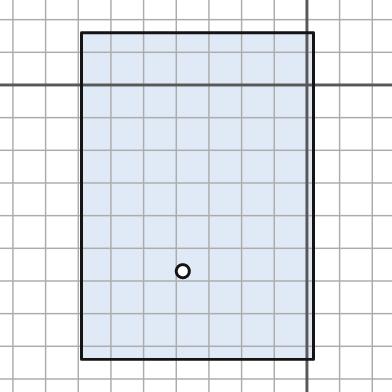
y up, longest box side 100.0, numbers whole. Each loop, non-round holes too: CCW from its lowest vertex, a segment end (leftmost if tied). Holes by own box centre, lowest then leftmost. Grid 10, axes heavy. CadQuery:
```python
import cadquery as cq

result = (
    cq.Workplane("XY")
    .moveTo(-69.0, -84.0)
    .lineTo(2.0, -84.0)
    .lineTo(2.0, 16.0)
    .lineTo(-69.0, 16.0)
    .close()
    .moveTo(-38.0, -57.0)
    .circle(2.0)
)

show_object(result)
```